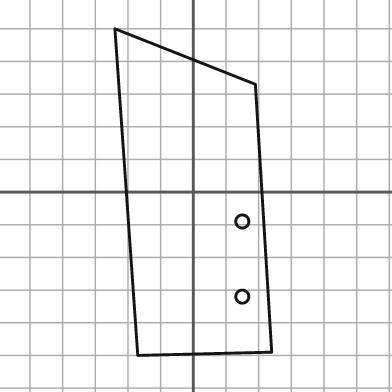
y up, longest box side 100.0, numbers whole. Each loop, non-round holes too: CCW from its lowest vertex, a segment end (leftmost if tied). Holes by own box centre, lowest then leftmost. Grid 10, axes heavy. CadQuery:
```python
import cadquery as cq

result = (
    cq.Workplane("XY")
    .moveTo(-17.0, -50.0)
    .lineTo(24.0, -49.0)
    .lineTo(19.0, 33.0)
    .lineTo(-24.0, 50.0)
    .close()
    .moveTo(15.0, -32.0)
    .circle(2.0)
    .moveTo(15.0, -9.0)
    .circle(2.0)
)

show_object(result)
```